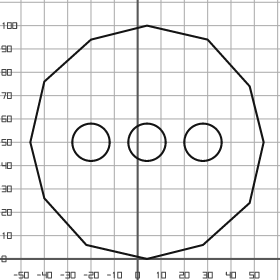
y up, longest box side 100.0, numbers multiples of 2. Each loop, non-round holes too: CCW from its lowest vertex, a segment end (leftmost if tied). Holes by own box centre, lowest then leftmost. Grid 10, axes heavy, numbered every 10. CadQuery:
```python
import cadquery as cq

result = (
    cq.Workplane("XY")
    .moveTo(4.0, 0.0)
    .lineTo(28.0, 6.0)
    .lineTo(48.0, 24.0)
    .lineTo(54.0, 50.0)
    .lineTo(48.0, 74.0)
    .lineTo(30.0, 94.0)
    .lineTo(4.0, 100.0)
    .lineTo(-20.0, 94.0)
    .lineTo(-40.0, 76.0)
    .lineTo(-46.0, 50.0)
    .lineTo(-40.0, 26.0)
    .lineTo(-22.0, 6.0)
    .close()
    .moveTo(-20.0, 50.0)
    .circle(8.0)
    .moveTo(4.0, 50.0)
    .circle(8.0)
    .moveTo(28.0, 50.0)
    .circle(8.0)
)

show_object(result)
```